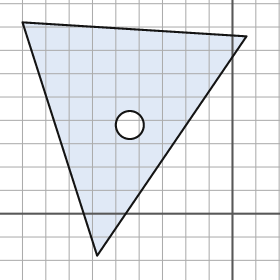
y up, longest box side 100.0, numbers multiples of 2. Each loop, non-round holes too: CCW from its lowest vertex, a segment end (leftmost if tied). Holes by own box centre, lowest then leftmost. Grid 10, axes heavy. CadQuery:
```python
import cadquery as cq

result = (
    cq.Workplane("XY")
    .moveTo(-58.0, -18.0)
    .lineTo(6.0, 76.0)
    .lineTo(-90.0, 82.0)
    .close()
    .moveTo(-44.0, 38.0)
    .circle(6.0)
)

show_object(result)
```